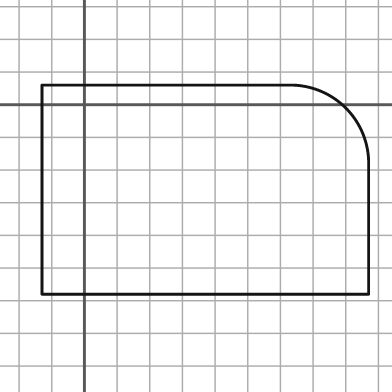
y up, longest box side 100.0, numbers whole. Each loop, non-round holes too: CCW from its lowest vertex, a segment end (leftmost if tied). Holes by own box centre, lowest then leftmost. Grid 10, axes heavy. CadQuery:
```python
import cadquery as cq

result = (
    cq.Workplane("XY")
    .moveTo(-13.0, -58.0)
    .lineTo(87.0, -58.0)
    .lineTo(87.0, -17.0)
    .threePointArc((80.0, -1.0), (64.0, 6.0))
    .lineTo(-13.0, 6.0)
    .close()
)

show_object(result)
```